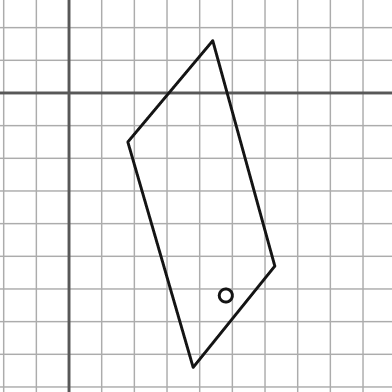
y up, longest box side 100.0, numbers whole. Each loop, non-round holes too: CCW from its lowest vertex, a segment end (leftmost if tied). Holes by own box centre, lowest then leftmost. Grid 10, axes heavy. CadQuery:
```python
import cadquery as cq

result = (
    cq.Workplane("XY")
    .moveTo(38.0, -84.0)
    .lineTo(63.0, -53.0)
    .lineTo(44.0, 16.0)
    .lineTo(18.0, -15.0)
    .close()
    .moveTo(48.0, -62.0)
    .circle(2.0)
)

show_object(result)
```